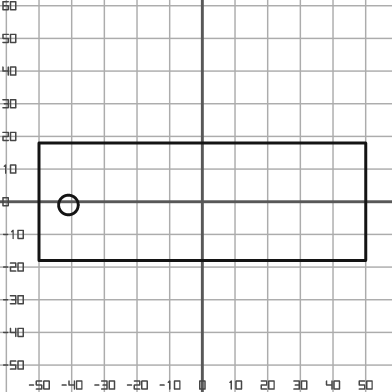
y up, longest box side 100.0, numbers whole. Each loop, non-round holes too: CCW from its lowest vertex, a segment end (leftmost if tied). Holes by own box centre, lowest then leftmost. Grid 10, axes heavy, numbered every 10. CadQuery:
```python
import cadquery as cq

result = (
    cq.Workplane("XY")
    .moveTo(-50.0, -18.0)
    .lineTo(50.0, -18.0)
    .lineTo(50.0, 18.0)
    .lineTo(-50.0, 18.0)
    .close()
    .moveTo(-41.0, -1.0)
    .circle(3.0)
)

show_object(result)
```